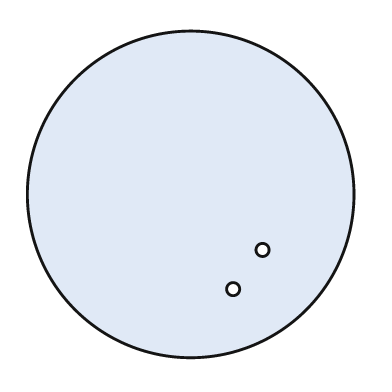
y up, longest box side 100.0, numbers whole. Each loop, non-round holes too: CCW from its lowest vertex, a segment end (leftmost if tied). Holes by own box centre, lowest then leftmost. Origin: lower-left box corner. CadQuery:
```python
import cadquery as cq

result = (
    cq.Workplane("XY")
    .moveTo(50.0, 50.0)
    .circle(50.0)
    .moveTo(63.0, 21.0)
    .circle(2.0)
    .moveTo(72.0, 33.0)
    .circle(2.0)
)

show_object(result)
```